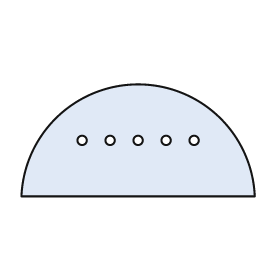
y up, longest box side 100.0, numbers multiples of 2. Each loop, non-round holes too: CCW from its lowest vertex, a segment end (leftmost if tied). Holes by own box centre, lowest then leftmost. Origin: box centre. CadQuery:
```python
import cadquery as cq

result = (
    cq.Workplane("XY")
    .moveTo(-50.0, -24.0)
    .lineTo(50.0, -24.0)
    .threePointArc((0.0, 24.0), (-50.0, -24.0))
    .close()
    .moveTo(-24.0, 0.0)
    .circle(2.0)
    .moveTo(-12.0, 0.0)
    .circle(2.0)
    .moveTo(0.0, 0.0)
    .circle(2.0)
    .moveTo(12.0, 0.0)
    .circle(2.0)
    .moveTo(24.0, 0.0)
    .circle(2.0)
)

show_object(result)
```